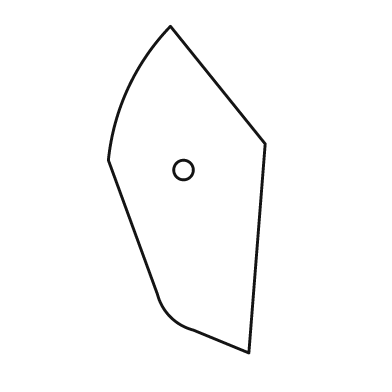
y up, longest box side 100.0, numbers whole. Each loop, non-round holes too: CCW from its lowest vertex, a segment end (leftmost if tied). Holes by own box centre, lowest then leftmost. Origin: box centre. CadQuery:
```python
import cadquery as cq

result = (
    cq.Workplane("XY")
    .moveTo(19.0, -50.0)
    .lineTo(24.0, 14.0)
    .lineTo(-5.0, 50.0)
    .threePointArc((-18.0, 31.0), (-24.0, 9.0))
    .lineTo(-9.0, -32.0)
    .threePointArc((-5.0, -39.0), (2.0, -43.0))
    .close()
    .moveTo(-1.0, 6.0)
    .circle(3.0)
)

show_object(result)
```